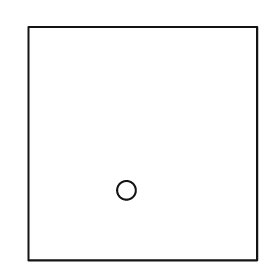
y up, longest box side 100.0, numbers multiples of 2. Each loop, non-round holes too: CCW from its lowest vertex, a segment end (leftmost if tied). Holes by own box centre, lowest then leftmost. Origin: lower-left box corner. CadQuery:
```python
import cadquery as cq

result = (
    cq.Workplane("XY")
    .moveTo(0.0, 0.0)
    .lineTo(98.0, 0.0)
    .lineTo(98.0, 100.0)
    .lineTo(0.0, 100.0)
    .close()
    .moveTo(42.0, 30.0)
    .circle(4.0)
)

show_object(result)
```